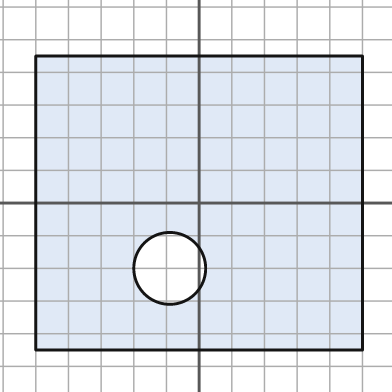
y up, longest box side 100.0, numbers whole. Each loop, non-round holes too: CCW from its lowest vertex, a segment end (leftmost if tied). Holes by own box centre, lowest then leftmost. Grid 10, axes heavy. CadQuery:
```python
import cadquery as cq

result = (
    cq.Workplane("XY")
    .moveTo(-50.0, -45.0)
    .lineTo(50.0, -45.0)
    .lineTo(50.0, 45.0)
    .lineTo(-50.0, 45.0)
    .close()
    .moveTo(-9.0, -20.0)
    .circle(11.0)
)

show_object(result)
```